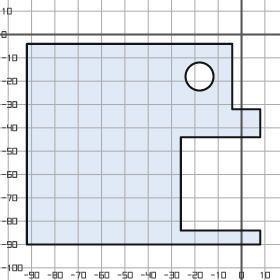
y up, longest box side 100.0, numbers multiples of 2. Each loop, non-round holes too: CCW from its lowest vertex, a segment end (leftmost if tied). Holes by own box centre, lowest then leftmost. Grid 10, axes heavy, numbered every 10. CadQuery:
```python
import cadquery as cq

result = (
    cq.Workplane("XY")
    .moveTo(-92.0, -90.0)
    .lineTo(8.0, -90.0)
    .lineTo(8.0, -84.0)
    .lineTo(-26.0, -84.0)
    .lineTo(-26.0, -44.0)
    .lineTo(8.0, -44.0)
    .lineTo(8.0, -32.0)
    .lineTo(-4.0, -32.0)
    .lineTo(-4.0, -4.0)
    .lineTo(-92.0, -4.0)
    .close()
    .moveTo(-18.0, -18.0)
    .circle(6.0)
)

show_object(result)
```